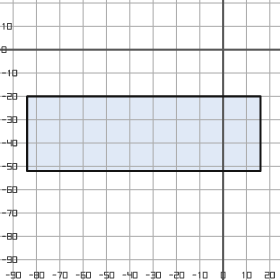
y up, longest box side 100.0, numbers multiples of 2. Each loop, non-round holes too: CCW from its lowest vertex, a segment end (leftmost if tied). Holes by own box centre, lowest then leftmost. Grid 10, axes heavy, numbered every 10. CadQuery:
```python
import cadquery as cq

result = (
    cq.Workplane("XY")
    .moveTo(-84.0, -52.0)
    .lineTo(16.0, -52.0)
    .lineTo(16.0, -20.0)
    .lineTo(-84.0, -20.0)
    .close()
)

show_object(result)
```